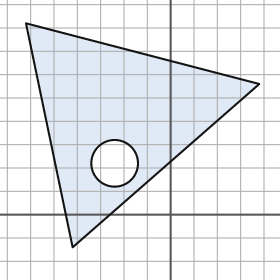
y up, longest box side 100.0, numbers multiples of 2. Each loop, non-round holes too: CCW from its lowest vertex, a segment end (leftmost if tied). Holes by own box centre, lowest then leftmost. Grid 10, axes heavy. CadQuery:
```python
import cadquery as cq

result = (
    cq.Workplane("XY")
    .moveTo(-42.0, -14.0)
    .lineTo(38.0, 56.0)
    .lineTo(-62.0, 82.0)
    .close()
    .moveTo(-24.0, 22.0)
    .circle(10.0)
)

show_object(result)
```